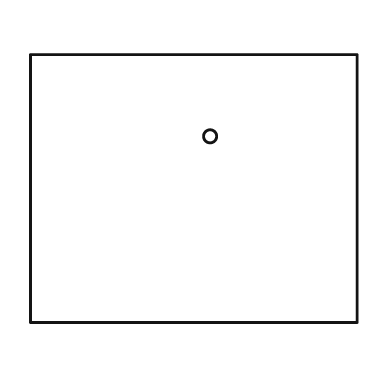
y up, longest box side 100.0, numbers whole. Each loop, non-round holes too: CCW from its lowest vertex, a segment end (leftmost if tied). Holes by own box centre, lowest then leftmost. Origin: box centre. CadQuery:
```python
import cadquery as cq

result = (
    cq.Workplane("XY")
    .moveTo(-50.0, -41.0)
    .lineTo(50.0, -41.0)
    .lineTo(50.0, 41.0)
    .lineTo(-50.0, 41.0)
    .close()
    .moveTo(5.0, 16.0)
    .circle(2.0)
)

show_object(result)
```